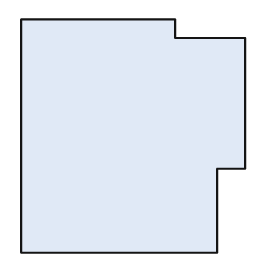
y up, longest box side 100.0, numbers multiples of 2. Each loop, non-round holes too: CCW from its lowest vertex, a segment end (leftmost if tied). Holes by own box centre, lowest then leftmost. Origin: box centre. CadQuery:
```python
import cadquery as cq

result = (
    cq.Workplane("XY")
    .moveTo(-48.0, -50.0)
    .lineTo(36.0, -50.0)
    .lineTo(36.0, -14.0)
    .lineTo(48.0, -14.0)
    .lineTo(48.0, 42.0)
    .lineTo(18.0, 42.0)
    .lineTo(18.0, 50.0)
    .lineTo(-48.0, 50.0)
    .close()
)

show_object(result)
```